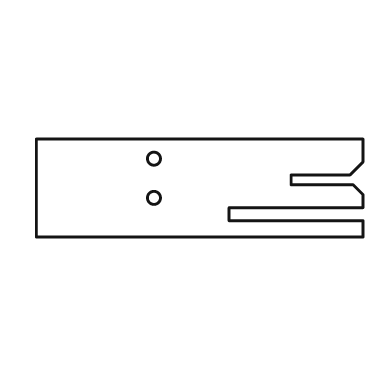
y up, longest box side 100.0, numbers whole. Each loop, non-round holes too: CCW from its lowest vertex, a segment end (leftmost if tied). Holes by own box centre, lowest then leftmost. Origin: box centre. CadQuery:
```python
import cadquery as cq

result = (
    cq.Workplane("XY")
    .moveTo(-50.0, -15.0)
    .lineTo(50.0, -15.0)
    .lineTo(50.0, -10.0)
    .lineTo(9.0, -10.0)
    .lineTo(9.0, -6.0)
    .lineTo(50.0, -6.0)
    .lineTo(50.0, -2.0)
    .lineTo(47.0, 1.0)
    .lineTo(28.0, 1.0)
    .lineTo(28.0, 4.0)
    .lineTo(46.0, 4.0)
    .lineTo(50.0, 8.0)
    .lineTo(50.0, 15.0)
    .lineTo(-50.0, 15.0)
    .close()
    .moveTo(-14.0, -3.0)
    .circle(2.0)
    .moveTo(-14.0, 9.0)
    .circle(2.0)
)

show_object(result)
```